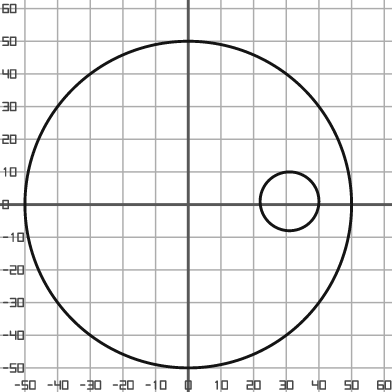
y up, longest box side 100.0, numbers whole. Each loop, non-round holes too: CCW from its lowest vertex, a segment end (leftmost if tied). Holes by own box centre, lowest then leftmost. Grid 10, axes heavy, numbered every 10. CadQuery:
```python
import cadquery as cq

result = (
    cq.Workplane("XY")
    .moveTo(0.0, 0.0)
    .circle(50.0)
    .moveTo(31.0, 1.0)
    .circle(9.0)
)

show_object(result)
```